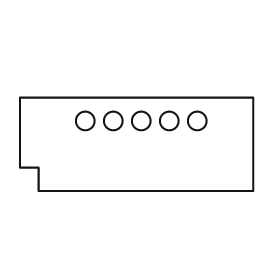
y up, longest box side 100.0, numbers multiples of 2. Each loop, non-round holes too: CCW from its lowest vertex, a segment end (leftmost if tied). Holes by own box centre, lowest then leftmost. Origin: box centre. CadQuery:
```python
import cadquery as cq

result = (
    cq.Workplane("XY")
    .moveTo(-42.0, -20.0)
    .lineTo(50.0, -20.0)
    .lineTo(50.0, 20.0)
    .lineTo(-50.0, 20.0)
    .lineTo(-50.0, -10.0)
    .lineTo(-42.0, -10.0)
    .close()
    .moveTo(-22.0, 10.0)
    .circle(4.0)
    .moveTo(-10.0, 10.0)
    .circle(4.0)
    .moveTo(2.0, 10.0)
    .circle(4.0)
    .moveTo(14.0, 10.0)
    .circle(4.0)
    .moveTo(26.0, 10.0)
    .circle(4.0)
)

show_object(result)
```